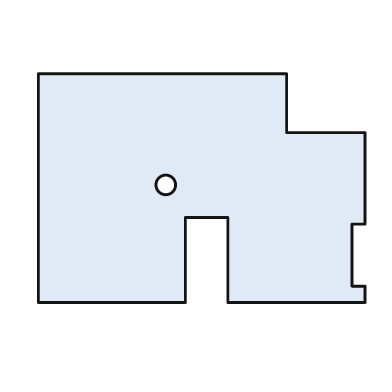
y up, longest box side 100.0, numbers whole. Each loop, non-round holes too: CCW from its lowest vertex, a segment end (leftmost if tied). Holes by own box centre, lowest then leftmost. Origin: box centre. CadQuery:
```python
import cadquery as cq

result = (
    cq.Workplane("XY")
    .moveTo(-50.0, -35.0)
    .lineTo(-5.0, -35.0)
    .lineTo(-5.0, -9.0)
    .lineTo(8.0, -9.0)
    .lineTo(8.0, -35.0)
    .lineTo(50.0, -35.0)
    .lineTo(50.0, -30.0)
    .lineTo(46.0, -30.0)
    .lineTo(46.0, -11.0)
    .lineTo(50.0, -11.0)
    .lineTo(50.0, 17.0)
    .lineTo(26.0, 17.0)
    .lineTo(26.0, 35.0)
    .lineTo(-50.0, 35.0)
    .close()
    .moveTo(-11.0, 1.0)
    .circle(3.0)
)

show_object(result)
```